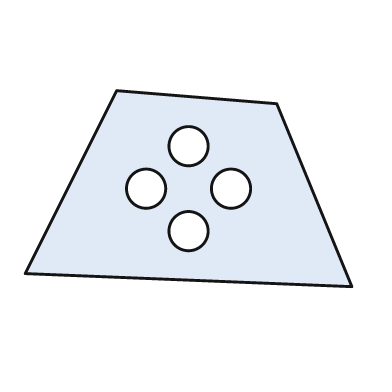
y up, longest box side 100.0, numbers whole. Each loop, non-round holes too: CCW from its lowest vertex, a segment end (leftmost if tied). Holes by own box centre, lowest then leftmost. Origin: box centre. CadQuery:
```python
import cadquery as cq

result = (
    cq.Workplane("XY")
    .moveTo(50.0, -30.0)
    .lineTo(27.0, 26.0)
    .lineTo(-22.0, 30.0)
    .lineTo(-50.0, -26.0)
    .close()
    .moveTo(0.0, -13.0)
    .circle(6.0)
    .moveTo(-13.0, 0.0)
    .circle(6.0)
    .moveTo(13.0, 0.0)
    .circle(6.0)
    .moveTo(0.0, 13.0)
    .circle(6.0)
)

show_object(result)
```